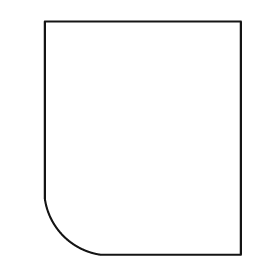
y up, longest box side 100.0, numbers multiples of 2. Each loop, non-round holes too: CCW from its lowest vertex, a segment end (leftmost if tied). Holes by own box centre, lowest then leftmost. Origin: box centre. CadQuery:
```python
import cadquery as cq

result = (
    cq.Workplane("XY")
    .moveTo(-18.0, -50.0)
    .lineTo(42.0, -50.0)
    .lineTo(42.0, 50.0)
    .lineTo(-42.0, 50.0)
    .lineTo(-42.0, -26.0)
    .threePointArc((-34.0, -42.0), (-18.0, -50.0))
    .close()
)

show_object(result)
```